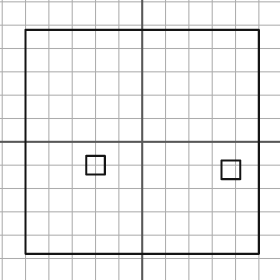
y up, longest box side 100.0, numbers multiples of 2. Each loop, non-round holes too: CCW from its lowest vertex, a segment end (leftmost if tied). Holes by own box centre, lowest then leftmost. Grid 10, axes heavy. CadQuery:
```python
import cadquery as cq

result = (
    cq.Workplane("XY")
    .moveTo(-50.0, -48.0)
    .lineTo(50.0, -48.0)
    .lineTo(50.0, 48.0)
    .lineTo(-50.0, 48.0)
    .close()
    .moveTo(34.0, -16.0)
    .lineTo(42.0, -16.0)
    .lineTo(42.0, -8.0)
    .lineTo(34.0, -8.0)
    .close()
    .moveTo(-24.0, -14.0)
    .lineTo(-16.0, -14.0)
    .lineTo(-16.0, -6.0)
    .lineTo(-24.0, -6.0)
    .close()
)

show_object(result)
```